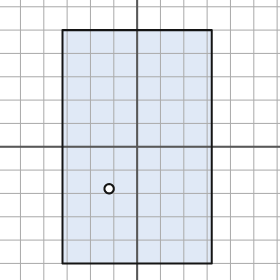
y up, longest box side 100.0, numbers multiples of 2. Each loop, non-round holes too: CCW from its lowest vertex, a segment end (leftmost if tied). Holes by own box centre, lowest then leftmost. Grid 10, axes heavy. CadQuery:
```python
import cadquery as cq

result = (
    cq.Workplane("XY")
    .moveTo(-32.0, -50.0)
    .lineTo(32.0, -50.0)
    .lineTo(32.0, 50.0)
    .lineTo(-32.0, 50.0)
    .close()
    .moveTo(-12.0, -18.0)
    .circle(2.0)
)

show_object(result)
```